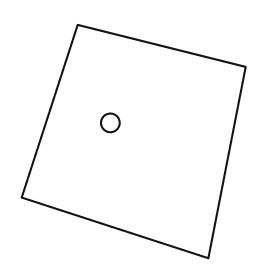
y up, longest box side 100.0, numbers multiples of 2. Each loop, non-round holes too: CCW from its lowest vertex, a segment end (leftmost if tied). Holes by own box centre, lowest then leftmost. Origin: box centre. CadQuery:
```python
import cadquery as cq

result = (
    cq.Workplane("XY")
    .moveTo(32.0, -50.0)
    .lineTo(48.0, 32.0)
    .lineTo(-24.0, 50.0)
    .lineTo(-48.0, -24.0)
    .close()
    .moveTo(-10.0, 8.0)
    .circle(4.0)
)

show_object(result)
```